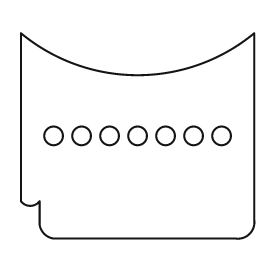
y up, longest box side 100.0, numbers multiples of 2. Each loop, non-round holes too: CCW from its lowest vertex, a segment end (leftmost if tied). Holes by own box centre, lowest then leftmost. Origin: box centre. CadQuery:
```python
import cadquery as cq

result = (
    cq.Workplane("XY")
    .moveTo(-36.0, -44.0)
    .lineTo(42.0, -44.0)
    .threePointArc((48.0, -42.0), (50.0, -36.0))
    .lineTo(50.0, 44.0)
    .threePointArc((0.0, 26.0), (-50.0, 44.0))
    .lineTo(-50.0, -28.0)
    .threePointArc((-46.0, -30.0), (-42.0, -28.0))
    .lineTo(-42.0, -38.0)
    .threePointArc((-40.0, -42.0), (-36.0, -44.0))
    .close()
    .moveTo(-36.0, 0.0)
    .circle(4.0)
    .moveTo(-24.0, 0.0)
    .circle(4.0)
    .moveTo(-12.0, 0.0)
    .circle(4.0)
    .moveTo(0.0, 0.0)
    .circle(4.0)
    .moveTo(12.0, 0.0)
    .circle(4.0)
    .moveTo(24.0, 0.0)
    .circle(4.0)
    .moveTo(36.0, 0.0)
    .circle(4.0)
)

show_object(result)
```